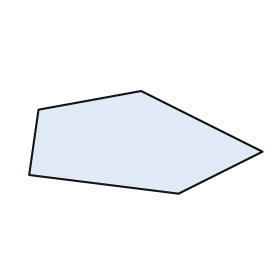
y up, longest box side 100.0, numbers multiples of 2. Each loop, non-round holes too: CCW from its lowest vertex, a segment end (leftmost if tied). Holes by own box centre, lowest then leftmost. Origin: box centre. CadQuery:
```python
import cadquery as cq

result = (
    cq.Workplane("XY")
    .moveTo(14.0, -22.0)
    .lineTo(50.0, -4.0)
    .lineTo(-2.0, 22.0)
    .lineTo(-46.0, 14.0)
    .lineTo(-50.0, -14.0)
    .close()
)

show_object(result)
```